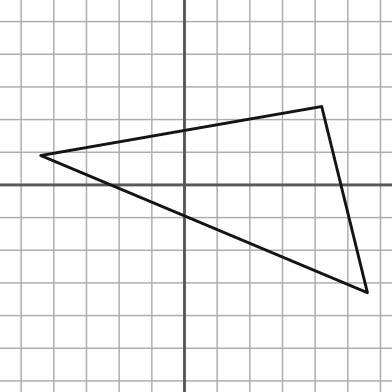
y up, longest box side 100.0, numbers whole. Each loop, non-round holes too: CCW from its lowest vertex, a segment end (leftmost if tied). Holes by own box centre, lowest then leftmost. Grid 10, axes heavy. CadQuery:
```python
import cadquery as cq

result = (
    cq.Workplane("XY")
    .moveTo(56.0, -33.0)
    .lineTo(42.0, 24.0)
    .lineTo(-44.0, 9.0)
    .close()
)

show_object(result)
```